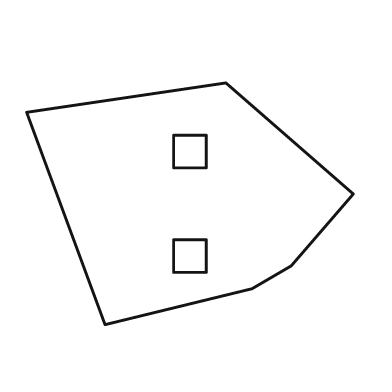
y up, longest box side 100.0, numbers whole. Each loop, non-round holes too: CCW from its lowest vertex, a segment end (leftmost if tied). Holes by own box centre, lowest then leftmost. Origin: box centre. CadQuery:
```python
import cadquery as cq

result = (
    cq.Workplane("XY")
    .moveTo(-26.0, -37.0)
    .lineTo(19.0, -26.0)
    .lineTo(31.0, -19.0)
    .lineTo(50.0, 3.0)
    .lineTo(11.0, 37.0)
    .lineTo(-50.0, 28.0)
    .close()
    .moveTo(-5.0, -21.0)
    .lineTo(5.0, -21.0)
    .lineTo(5.0, -11.0)
    .lineTo(-5.0, -11.0)
    .close()
    .moveTo(-5.0, 11.0)
    .lineTo(5.0, 11.0)
    .lineTo(5.0, 21.0)
    .lineTo(-5.0, 21.0)
    .close()
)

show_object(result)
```